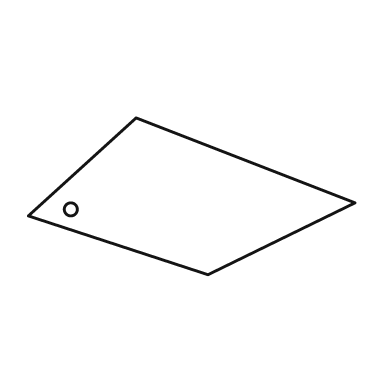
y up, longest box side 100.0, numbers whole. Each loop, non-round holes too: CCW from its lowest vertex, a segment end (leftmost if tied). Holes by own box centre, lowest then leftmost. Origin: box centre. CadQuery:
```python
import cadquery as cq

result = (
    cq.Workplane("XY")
    .moveTo(5.0, -24.0)
    .lineTo(50.0, -2.0)
    .lineTo(-17.0, 24.0)
    .lineTo(-50.0, -6.0)
    .close()
    .moveTo(-37.0, -4.0)
    .circle(2.0)
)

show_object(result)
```